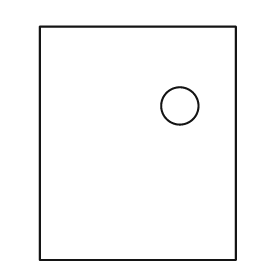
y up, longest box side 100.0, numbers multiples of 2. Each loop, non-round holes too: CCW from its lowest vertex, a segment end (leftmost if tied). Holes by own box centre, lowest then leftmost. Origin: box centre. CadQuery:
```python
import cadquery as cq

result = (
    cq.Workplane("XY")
    .moveTo(-42.0, -50.0)
    .lineTo(42.0, -50.0)
    .lineTo(42.0, 50.0)
    .lineTo(-42.0, 50.0)
    .close()
    .moveTo(18.0, 16.0)
    .circle(8.0)
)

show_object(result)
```